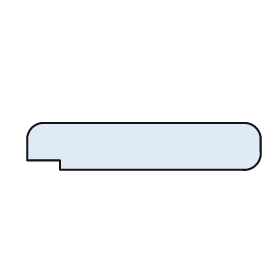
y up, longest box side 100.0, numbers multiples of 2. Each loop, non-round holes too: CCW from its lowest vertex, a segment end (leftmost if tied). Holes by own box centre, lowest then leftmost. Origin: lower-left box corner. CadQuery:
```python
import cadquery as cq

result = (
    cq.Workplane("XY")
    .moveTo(14.0, 0.0)
    .lineTo(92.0, 0.0)
    .threePointArc((98.0, 2.0), (100.0, 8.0))
    .lineTo(100.0, 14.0)
    .threePointArc((98.0, 18.0), (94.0, 20.0))
    .lineTo(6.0, 20.0)
    .threePointArc((2.0, 18.0), (0.0, 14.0))
    .lineTo(0.0, 4.0)
    .lineTo(14.0, 4.0)
    .close()
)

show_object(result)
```